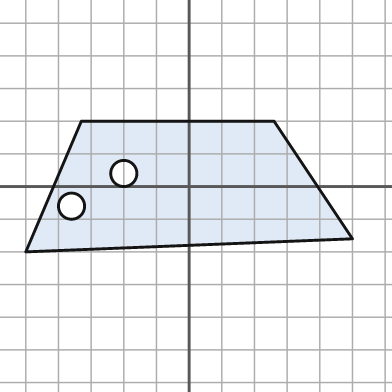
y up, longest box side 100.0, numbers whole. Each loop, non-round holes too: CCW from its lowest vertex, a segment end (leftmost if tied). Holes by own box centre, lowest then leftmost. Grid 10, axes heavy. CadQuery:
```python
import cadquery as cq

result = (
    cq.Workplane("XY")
    .moveTo(-50.0, -20.0)
    .lineTo(50.0, -16.0)
    .lineTo(26.0, 20.0)
    .lineTo(-33.0, 20.0)
    .close()
    .moveTo(-36.0, -6.0)
    .circle(4.0)
    .moveTo(-20.0, 4.0)
    .circle(4.0)
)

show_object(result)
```